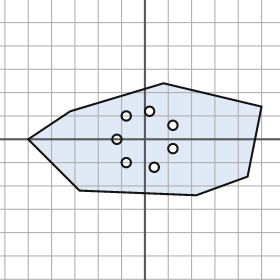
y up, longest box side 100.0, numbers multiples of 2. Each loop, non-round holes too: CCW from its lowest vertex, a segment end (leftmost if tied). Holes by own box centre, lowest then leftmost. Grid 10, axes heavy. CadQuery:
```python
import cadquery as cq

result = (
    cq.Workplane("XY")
    .moveTo(22.0, -24.0)
    .lineTo(44.0, -16.0)
    .lineTo(50.0, 14.0)
    .lineTo(8.0, 24.0)
    .lineTo(-32.0, 12.0)
    .lineTo(-50.0, 0.0)
    .lineTo(-28.0, -22.0)
    .close()
    .moveTo(4.0, -12.0)
    .circle(2.0)
    .moveTo(-8.0, -10.0)
    .circle(2.0)
    .moveTo(12.0, -4.0)
    .circle(2.0)
    .moveTo(-12.0, 0.0)
    .circle(2.0)
    .moveTo(12.0, 6.0)
    .circle(2.0)
    .moveTo(-8.0, 10.0)
    .circle(2.0)
    .moveTo(2.0, 12.0)
    .circle(2.0)
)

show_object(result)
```